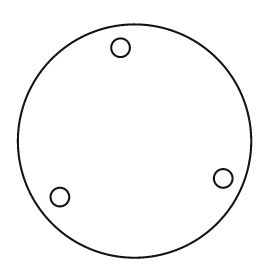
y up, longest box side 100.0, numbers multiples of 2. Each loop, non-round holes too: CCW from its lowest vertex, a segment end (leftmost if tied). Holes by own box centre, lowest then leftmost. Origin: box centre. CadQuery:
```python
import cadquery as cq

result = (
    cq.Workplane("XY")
    .moveTo(0.0, 0.0)
    .circle(50.0)
    .moveTo(-32.0, -24.0)
    .circle(4.0)
    .moveTo(38.0, -16.0)
    .circle(4.0)
    .moveTo(-6.0, 40.0)
    .circle(4.0)
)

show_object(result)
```